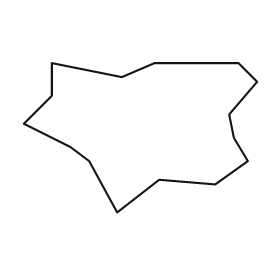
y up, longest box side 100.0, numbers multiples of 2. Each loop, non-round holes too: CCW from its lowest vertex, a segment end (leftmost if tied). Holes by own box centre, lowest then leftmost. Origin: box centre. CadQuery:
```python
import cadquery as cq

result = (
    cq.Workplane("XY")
    .moveTo(-10.0, -32.0)
    .lineTo(8.0, -18.0)
    .lineTo(32.0, -20.0)
    .lineTo(46.0, -10.0)
    .lineTo(40.0, 0.0)
    .lineTo(38.0, 10.0)
    .lineTo(50.0, 24.0)
    .lineTo(42.0, 32.0)
    .lineTo(6.0, 32.0)
    .lineTo(-8.0, 26.0)
    .lineTo(-38.0, 32.0)
    .lineTo(-38.0, 18.0)
    .lineTo(-50.0, 6.0)
    .lineTo(-30.0, -4.0)
    .lineTo(-22.0, -10.0)
    .close()
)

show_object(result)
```